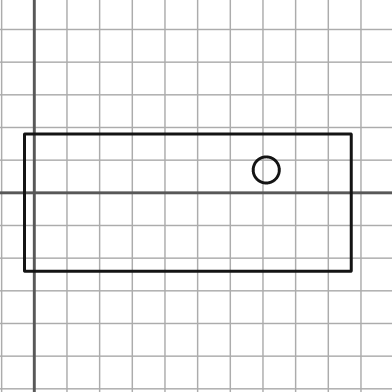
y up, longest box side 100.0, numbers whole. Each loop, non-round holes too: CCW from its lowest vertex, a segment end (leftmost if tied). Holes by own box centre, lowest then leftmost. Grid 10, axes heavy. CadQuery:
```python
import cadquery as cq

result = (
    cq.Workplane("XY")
    .moveTo(-3.0, -24.0)
    .lineTo(97.0, -24.0)
    .lineTo(97.0, 18.0)
    .lineTo(-3.0, 18.0)
    .close()
    .moveTo(71.0, 7.0)
    .circle(4.0)
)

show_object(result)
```